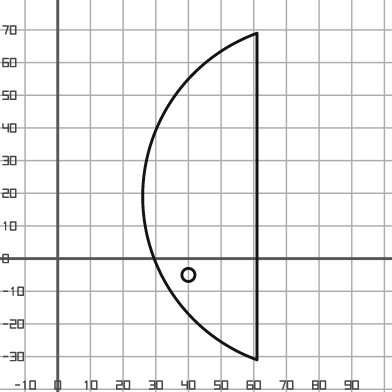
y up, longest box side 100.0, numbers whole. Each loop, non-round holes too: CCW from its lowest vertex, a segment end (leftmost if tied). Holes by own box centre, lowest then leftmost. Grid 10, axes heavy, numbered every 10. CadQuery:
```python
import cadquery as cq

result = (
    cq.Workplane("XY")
    .moveTo(61.0, -31.0)
    .lineTo(61.0, 69.0)
    .threePointArc((26.0, 19.0), (61.0, -31.0))
    .close()
    .moveTo(40.0, -5.0)
    .circle(2.0)
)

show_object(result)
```